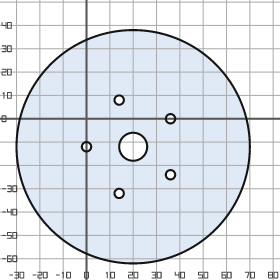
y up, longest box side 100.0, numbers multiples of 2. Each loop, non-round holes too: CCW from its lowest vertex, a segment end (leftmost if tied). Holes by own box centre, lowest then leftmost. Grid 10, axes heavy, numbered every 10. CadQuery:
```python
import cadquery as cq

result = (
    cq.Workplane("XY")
    .moveTo(20.0, -12.0)
    .circle(50.0)
    .moveTo(14.0, -32.0)
    .circle(2.0)
    .moveTo(36.0, -24.0)
    .circle(2.0)
    .moveTo(0.0, -12.0)
    .circle(2.0)
    .moveTo(20.0, -12.0)
    .circle(6.0)
    .moveTo(36.0, 0.0)
    .circle(2.0)
    .moveTo(14.0, 8.0)
    .circle(2.0)
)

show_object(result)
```